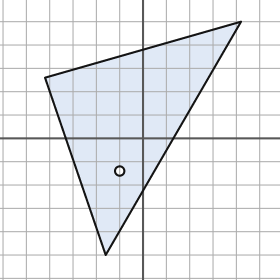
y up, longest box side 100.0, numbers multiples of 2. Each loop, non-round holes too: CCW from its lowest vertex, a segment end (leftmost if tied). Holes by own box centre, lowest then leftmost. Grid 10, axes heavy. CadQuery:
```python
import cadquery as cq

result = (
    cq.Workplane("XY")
    .moveTo(-16.0, -50.0)
    .lineTo(42.0, 50.0)
    .lineTo(-42.0, 26.0)
    .close()
    .moveTo(-10.0, -14.0)
    .circle(2.0)
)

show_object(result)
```